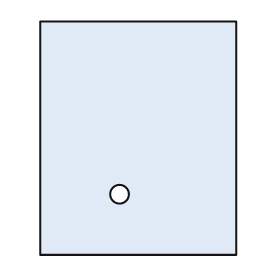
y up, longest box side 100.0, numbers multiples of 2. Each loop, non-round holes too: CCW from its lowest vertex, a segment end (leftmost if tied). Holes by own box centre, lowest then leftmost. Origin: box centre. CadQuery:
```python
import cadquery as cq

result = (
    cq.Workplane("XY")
    .moveTo(-42.0, -50.0)
    .lineTo(42.0, -50.0)
    .lineTo(42.0, 50.0)
    .lineTo(-42.0, 50.0)
    .close()
    .moveTo(-8.0, -24.0)
    .circle(4.0)
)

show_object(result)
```